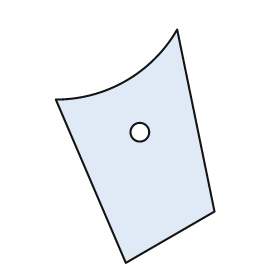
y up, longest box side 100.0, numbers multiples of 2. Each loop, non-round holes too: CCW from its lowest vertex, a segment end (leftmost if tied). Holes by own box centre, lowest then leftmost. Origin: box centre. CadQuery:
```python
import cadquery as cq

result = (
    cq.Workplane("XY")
    .moveTo(-4.0, -50.0)
    .lineTo(34.0, -28.0)
    .lineTo(18.0, 50.0)
    .threePointArc((-4.0, 28.0), (-34.0, 20.0))
    .close()
    .moveTo(2.0, 6.0)
    .circle(4.0)
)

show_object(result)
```